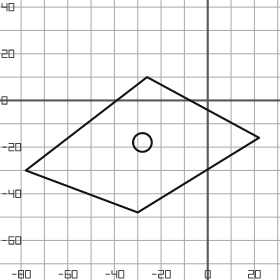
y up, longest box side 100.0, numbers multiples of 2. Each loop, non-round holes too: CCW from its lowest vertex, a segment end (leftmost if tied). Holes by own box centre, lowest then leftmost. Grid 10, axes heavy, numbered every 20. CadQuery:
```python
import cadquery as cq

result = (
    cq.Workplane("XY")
    .moveTo(-30.0, -48.0)
    .lineTo(22.0, -16.0)
    .lineTo(-26.0, 10.0)
    .lineTo(-78.0, -30.0)
    .close()
    .moveTo(-28.0, -18.0)
    .circle(4.0)
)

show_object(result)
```